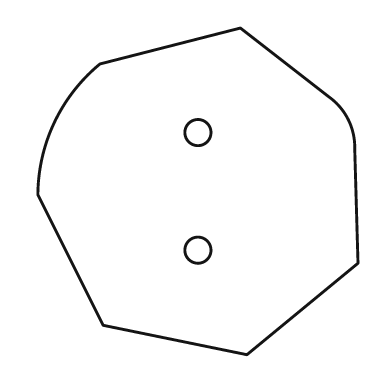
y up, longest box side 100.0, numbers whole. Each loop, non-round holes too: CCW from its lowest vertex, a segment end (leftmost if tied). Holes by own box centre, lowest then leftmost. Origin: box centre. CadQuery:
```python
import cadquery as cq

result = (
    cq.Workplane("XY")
    .moveTo(15.0, -50.0)
    .lineTo(49.0, -22.0)
    .lineTo(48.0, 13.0)
    .threePointArc((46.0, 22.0), (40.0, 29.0))
    .lineTo(13.0, 50.0)
    .lineTo(-30.0, 39.0)
    .threePointArc((-44.0, 21.0), (-49.0, -1.0))
    .lineTo(-29.0, -41.0)
    .close()
    .moveTo(0.0, -18.0)
    .circle(4.0)
    .moveTo(0.0, 18.0)
    .circle(4.0)
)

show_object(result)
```